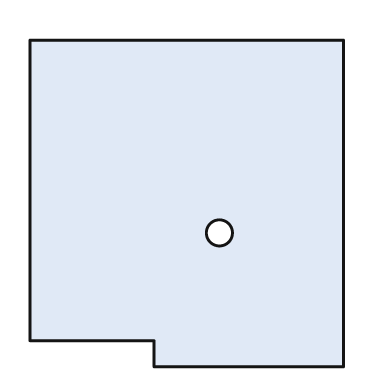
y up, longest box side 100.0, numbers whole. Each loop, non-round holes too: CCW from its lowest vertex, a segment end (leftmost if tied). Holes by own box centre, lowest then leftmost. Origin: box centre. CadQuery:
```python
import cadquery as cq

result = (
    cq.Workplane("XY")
    .moveTo(-10.0, -50.0)
    .lineTo(48.0, -50.0)
    .lineTo(48.0, 50.0)
    .lineTo(-48.0, 50.0)
    .lineTo(-48.0, -42.0)
    .lineTo(-10.0, -42.0)
    .close()
    .moveTo(10.0, -9.0)
    .circle(4.0)
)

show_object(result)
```